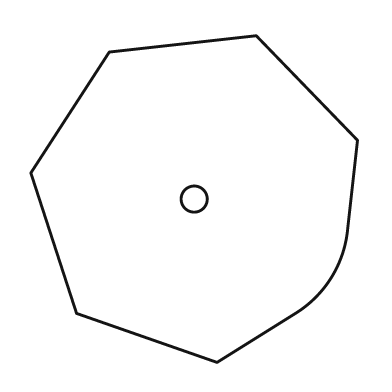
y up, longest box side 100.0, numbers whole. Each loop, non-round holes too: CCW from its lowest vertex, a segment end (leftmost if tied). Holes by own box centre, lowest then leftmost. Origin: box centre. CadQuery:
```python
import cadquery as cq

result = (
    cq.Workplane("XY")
    .moveTo(7.0, -50.0)
    .lineTo(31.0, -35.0)
    .threePointArc((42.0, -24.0), (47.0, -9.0))
    .lineTo(50.0, 18.0)
    .lineTo(19.0, 50.0)
    .lineTo(-26.0, 45.0)
    .lineTo(-50.0, 8.0)
    .lineTo(-36.0, -35.0)
    .close()
    .moveTo(0.0, 0.0)
    .circle(4.0)
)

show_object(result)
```